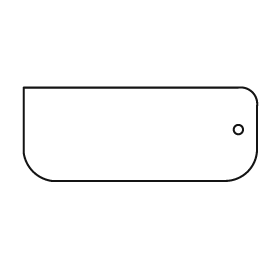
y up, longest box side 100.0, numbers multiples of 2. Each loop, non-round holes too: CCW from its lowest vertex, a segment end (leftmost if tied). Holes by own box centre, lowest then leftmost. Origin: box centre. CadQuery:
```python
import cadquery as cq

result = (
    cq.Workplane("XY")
    .moveTo(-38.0, -20.0)
    .lineTo(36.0, -20.0)
    .threePointArc((46.0, -16.0), (50.0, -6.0))
    .lineTo(50.0, 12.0)
    .threePointArc((48.0, 18.0), (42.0, 20.0))
    .lineTo(-50.0, 20.0)
    .lineTo(-50.0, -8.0)
    .threePointArc((-46.0, -16.0), (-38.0, -20.0))
    .close()
    .moveTo(42.0, 2.0)
    .circle(2.0)
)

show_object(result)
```